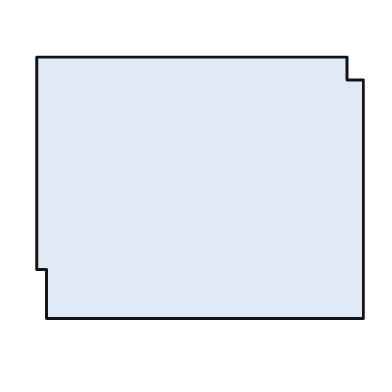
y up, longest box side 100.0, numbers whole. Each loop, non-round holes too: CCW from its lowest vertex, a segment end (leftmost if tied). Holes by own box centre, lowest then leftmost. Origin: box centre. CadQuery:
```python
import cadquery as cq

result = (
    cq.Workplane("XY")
    .moveTo(-47.0, -40.0)
    .lineTo(50.0, -40.0)
    .lineTo(50.0, 33.0)
    .lineTo(45.0, 33.0)
    .lineTo(45.0, 40.0)
    .lineTo(-50.0, 40.0)
    .lineTo(-50.0, -25.0)
    .lineTo(-47.0, -25.0)
    .close()
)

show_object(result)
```